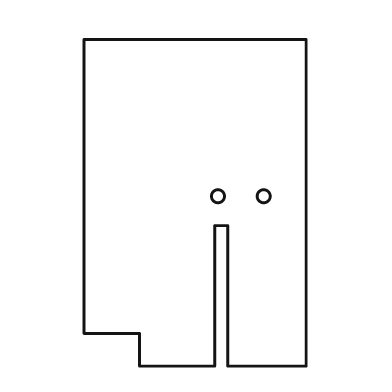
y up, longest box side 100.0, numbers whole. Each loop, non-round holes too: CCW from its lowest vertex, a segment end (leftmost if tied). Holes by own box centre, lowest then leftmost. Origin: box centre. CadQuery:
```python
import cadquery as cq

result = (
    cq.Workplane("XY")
    .moveTo(-17.0, -50.0)
    .lineTo(6.0, -50.0)
    .lineTo(6.0, -7.0)
    .lineTo(10.0, -7.0)
    .lineTo(10.0, -50.0)
    .lineTo(34.0, -50.0)
    .lineTo(34.0, 50.0)
    .lineTo(-34.0, 50.0)
    .lineTo(-34.0, -40.0)
    .lineTo(-17.0, -40.0)
    .close()
    .moveTo(7.0, 2.0)
    .circle(2.0)
    .moveTo(21.0, 2.0)
    .circle(2.0)
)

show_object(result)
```